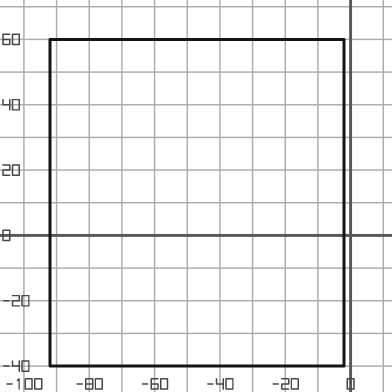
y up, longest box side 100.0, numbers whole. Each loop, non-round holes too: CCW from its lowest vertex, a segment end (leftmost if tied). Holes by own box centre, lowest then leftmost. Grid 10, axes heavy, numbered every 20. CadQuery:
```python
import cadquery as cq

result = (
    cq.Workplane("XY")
    .moveTo(-92.0, -40.0)
    .lineTo(-2.0, -40.0)
    .lineTo(-2.0, 60.0)
    .lineTo(-92.0, 60.0)
    .close()
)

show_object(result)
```